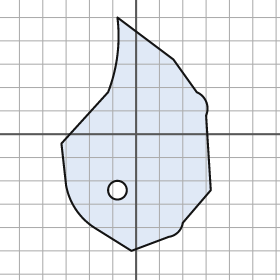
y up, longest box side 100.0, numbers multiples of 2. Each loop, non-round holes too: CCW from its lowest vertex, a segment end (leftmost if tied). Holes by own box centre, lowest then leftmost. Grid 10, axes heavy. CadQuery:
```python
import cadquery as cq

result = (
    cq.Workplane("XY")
    .moveTo(-2.0, -50.0)
    .lineTo(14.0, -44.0)
    .threePointArc((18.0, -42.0), (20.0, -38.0))
    .lineTo(32.0, -24.0)
    .lineTo(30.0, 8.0)
    .threePointArc((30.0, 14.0), (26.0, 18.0))
    .lineTo(16.0, 32.0)
    .lineTo(-8.0, 50.0)
    .threePointArc((-8.0, 34.0), (-12.0, 18.0))
    .lineTo(-32.0, -4.0)
    .lineTo(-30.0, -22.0)
    .threePointArc((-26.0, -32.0), (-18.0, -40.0))
    .close()
    .moveTo(-8.0, -24.0)
    .circle(4.0)
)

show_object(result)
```